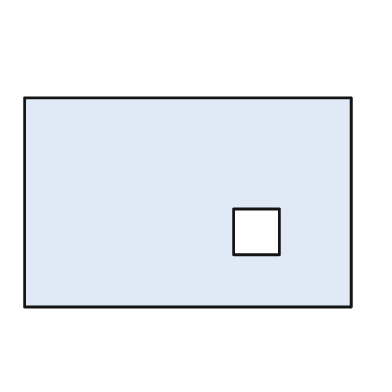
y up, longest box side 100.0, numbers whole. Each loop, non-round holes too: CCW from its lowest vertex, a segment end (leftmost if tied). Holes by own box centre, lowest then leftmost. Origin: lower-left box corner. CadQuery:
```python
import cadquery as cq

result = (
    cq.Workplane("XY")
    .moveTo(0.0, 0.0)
    .lineTo(100.0, 0.0)
    .lineTo(100.0, 64.0)
    .lineTo(0.0, 64.0)
    .close()
    .moveTo(64.0, 16.0)
    .lineTo(78.0, 16.0)
    .lineTo(78.0, 30.0)
    .lineTo(64.0, 30.0)
    .close()
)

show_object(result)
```